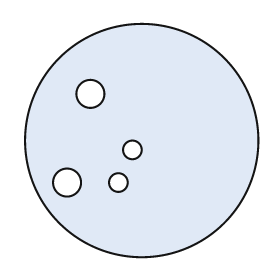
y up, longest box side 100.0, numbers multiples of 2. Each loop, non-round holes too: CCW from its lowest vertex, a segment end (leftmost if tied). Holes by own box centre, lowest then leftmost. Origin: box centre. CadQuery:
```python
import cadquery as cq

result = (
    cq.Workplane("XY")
    .moveTo(0.0, 0.0)
    .circle(50.0)
    .moveTo(-32.0, -18.0)
    .circle(6.0)
    .moveTo(-10.0, -18.0)
    .circle(4.0)
    .moveTo(-4.0, -4.0)
    .circle(4.0)
    .moveTo(-22.0, 20.0)
    .circle(6.0)
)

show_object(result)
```